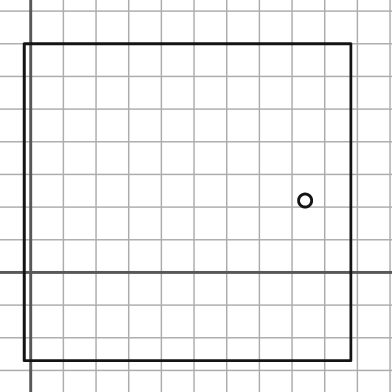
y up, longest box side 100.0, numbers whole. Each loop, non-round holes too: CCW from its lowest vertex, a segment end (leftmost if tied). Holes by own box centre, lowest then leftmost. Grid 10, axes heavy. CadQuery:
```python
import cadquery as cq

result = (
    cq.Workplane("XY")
    .moveTo(-2.0, -27.0)
    .lineTo(98.0, -27.0)
    .lineTo(98.0, 70.0)
    .lineTo(-2.0, 70.0)
    .close()
    .moveTo(84.0, 22.0)
    .circle(2.0)
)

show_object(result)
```